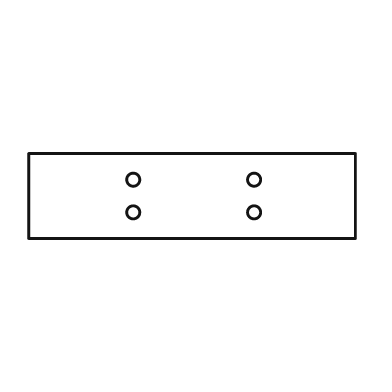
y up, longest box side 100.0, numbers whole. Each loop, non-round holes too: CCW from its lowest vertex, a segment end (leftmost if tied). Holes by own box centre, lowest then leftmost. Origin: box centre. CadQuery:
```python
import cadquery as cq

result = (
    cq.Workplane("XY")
    .moveTo(-50.0, -13.0)
    .lineTo(50.0, -13.0)
    .lineTo(50.0, 13.0)
    .lineTo(-50.0, 13.0)
    .close()
    .moveTo(-18.0, -5.0)
    .circle(2.0)
    .moveTo(19.0, -5.0)
    .circle(2.0)
    .moveTo(-18.0, 5.0)
    .circle(2.0)
    .moveTo(19.0, 5.0)
    .circle(2.0)
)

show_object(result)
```